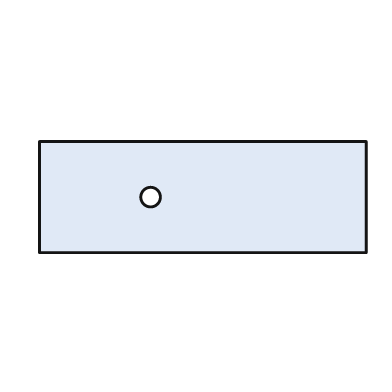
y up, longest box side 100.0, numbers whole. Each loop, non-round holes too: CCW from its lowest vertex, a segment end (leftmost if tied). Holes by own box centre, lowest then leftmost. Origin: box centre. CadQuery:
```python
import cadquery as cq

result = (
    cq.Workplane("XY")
    .moveTo(-50.0, -17.0)
    .lineTo(50.0, -17.0)
    .lineTo(50.0, 17.0)
    .lineTo(-50.0, 17.0)
    .close()
    .moveTo(-16.0, 0.0)
    .circle(3.0)
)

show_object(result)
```